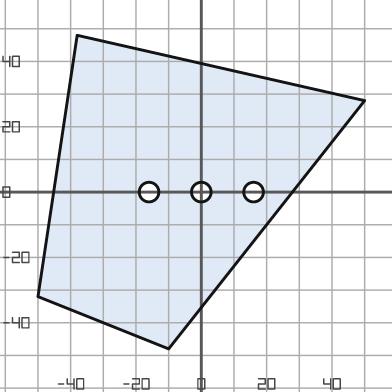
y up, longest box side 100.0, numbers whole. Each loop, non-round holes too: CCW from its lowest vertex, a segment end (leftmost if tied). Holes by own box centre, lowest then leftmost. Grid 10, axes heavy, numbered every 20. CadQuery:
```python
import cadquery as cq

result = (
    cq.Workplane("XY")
    .moveTo(-10.0, -48.0)
    .lineTo(50.0, 28.0)
    .lineTo(-38.0, 48.0)
    .lineTo(-50.0, -32.0)
    .close()
    .moveTo(-16.0, 0.0)
    .circle(3.0)
    .moveTo(0.0, 0.0)
    .circle(3.0)
    .moveTo(16.0, 0.0)
    .circle(3.0)
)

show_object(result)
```